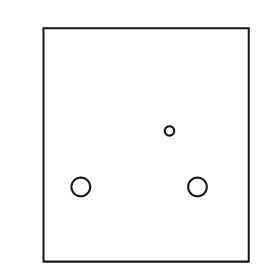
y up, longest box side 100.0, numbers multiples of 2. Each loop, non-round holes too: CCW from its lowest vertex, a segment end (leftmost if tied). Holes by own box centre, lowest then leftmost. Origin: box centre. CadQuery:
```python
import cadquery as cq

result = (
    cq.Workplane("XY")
    .moveTo(-44.0, -50.0)
    .lineTo(44.0, -50.0)
    .lineTo(44.0, 50.0)
    .lineTo(-44.0, 50.0)
    .close()
    .moveTo(-28.0, -18.0)
    .circle(4.0)
    .moveTo(22.0, -18.0)
    .circle(4.0)
    .moveTo(10.0, 6.0)
    .circle(2.0)
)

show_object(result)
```